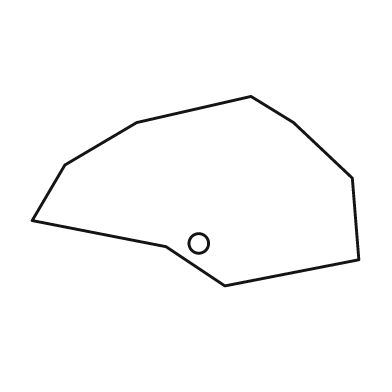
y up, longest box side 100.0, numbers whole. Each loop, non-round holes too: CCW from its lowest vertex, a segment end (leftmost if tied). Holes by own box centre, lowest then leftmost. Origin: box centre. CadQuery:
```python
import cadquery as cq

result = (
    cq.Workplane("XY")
    .moveTo(9.0, -29.0)
    .lineTo(50.0, -21.0)
    .lineTo(48.0, 4.0)
    .lineTo(30.0, 21.0)
    .lineTo(17.0, 29.0)
    .lineTo(-18.0, 21.0)
    .lineTo(-40.0, 8.0)
    .lineTo(-50.0, -9.0)
    .lineTo(-9.0, -17.0)
    .close()
    .moveTo(1.0, -16.0)
    .circle(3.0)
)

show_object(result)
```